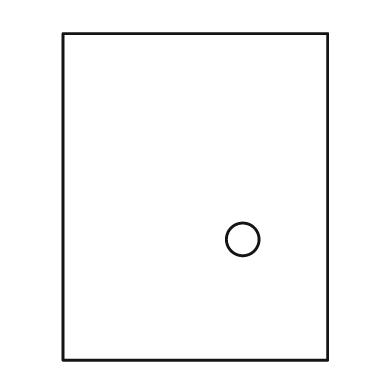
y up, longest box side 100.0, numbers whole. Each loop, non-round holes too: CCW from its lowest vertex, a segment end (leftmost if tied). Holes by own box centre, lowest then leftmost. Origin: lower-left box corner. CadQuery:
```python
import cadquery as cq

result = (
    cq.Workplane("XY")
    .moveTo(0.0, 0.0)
    .lineTo(81.0, 0.0)
    .lineTo(81.0, 100.0)
    .lineTo(0.0, 100.0)
    .close()
    .moveTo(55.0, 37.0)
    .circle(5.0)
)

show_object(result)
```